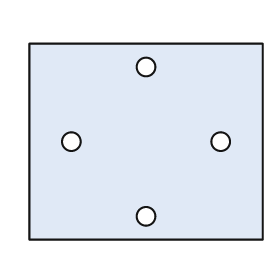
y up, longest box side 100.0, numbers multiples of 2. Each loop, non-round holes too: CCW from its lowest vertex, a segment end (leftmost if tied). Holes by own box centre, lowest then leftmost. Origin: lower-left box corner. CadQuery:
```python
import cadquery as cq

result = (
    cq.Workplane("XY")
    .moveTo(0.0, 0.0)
    .lineTo(100.0, 0.0)
    .lineTo(100.0, 84.0)
    .lineTo(0.0, 84.0)
    .close()
    .moveTo(50.0, 10.0)
    .circle(4.0)
    .moveTo(18.0, 42.0)
    .circle(4.0)
    .moveTo(82.0, 42.0)
    .circle(4.0)
    .moveTo(50.0, 74.0)
    .circle(4.0)
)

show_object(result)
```